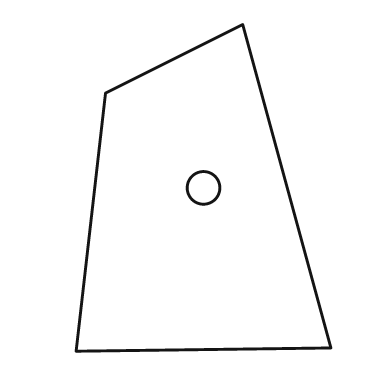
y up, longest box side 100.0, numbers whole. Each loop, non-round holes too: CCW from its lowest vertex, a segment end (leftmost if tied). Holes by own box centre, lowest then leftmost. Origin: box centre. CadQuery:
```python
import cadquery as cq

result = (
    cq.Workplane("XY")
    .moveTo(-39.0, -50.0)
    .lineTo(39.0, -49.0)
    .lineTo(12.0, 50.0)
    .lineTo(-30.0, 29.0)
    .close()
    .moveTo(0.0, 0.0)
    .circle(5.0)
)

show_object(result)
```